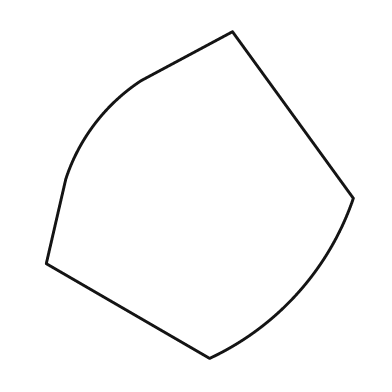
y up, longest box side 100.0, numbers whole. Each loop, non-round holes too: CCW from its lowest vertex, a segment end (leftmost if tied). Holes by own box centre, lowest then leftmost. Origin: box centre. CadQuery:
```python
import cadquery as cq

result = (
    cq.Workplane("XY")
    .moveTo(3.0, -50.0)
    .threePointArc((30.0, -30.0), (47.0, -1.0))
    .lineTo(10.0, 50.0)
    .lineTo(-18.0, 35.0)
    .threePointArc((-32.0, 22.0), (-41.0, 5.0))
    .lineTo(-47.0, -21.0)
    .close()
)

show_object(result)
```